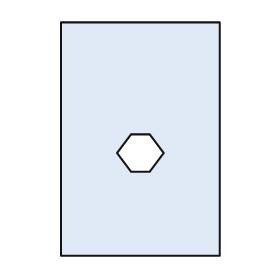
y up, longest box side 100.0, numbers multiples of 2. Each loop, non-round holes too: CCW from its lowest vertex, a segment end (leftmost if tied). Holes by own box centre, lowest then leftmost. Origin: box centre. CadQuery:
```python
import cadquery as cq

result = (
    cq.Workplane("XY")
    .moveTo(-34.0, -50.0)
    .lineTo(34.0, -50.0)
    .lineTo(34.0, 50.0)
    .lineTo(-34.0, 50.0)
    .close()
    .moveTo(-4.0, -14.0)
    .lineTo(4.0, -14.0)
    .lineTo(10.0, -6.0)
    .lineTo(4.0, 2.0)
    .lineTo(-4.0, 2.0)
    .lineTo(-10.0, -6.0)
    .close()
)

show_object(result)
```